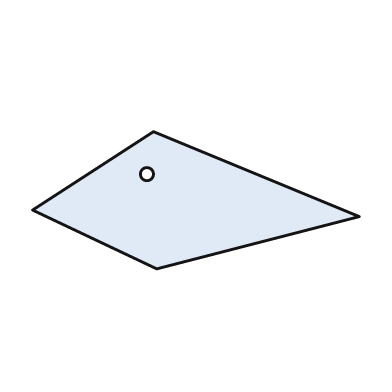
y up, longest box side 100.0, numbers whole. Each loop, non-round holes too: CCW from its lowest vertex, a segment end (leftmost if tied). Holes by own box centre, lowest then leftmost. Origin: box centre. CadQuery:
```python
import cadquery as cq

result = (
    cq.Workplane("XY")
    .moveTo(-12.0, -21.0)
    .lineTo(50.0, -5.0)
    .lineTo(-13.0, 21.0)
    .lineTo(-50.0, -3.0)
    .close()
    .moveTo(-15.0, 8.0)
    .circle(2.0)
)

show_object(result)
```